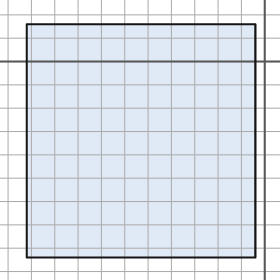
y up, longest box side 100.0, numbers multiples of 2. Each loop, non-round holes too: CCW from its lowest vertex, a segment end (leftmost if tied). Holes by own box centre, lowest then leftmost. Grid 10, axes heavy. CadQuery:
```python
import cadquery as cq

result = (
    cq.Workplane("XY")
    .moveTo(-102.0, -84.0)
    .lineTo(-4.0, -84.0)
    .lineTo(-4.0, 16.0)
    .lineTo(-102.0, 16.0)
    .close()
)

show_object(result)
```